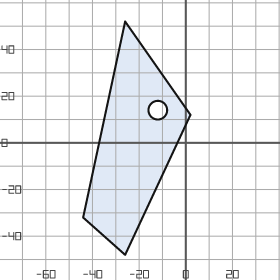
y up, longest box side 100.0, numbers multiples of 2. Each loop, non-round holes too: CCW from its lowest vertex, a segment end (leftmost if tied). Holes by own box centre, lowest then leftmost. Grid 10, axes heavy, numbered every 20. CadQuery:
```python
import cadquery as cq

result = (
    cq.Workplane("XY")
    .moveTo(-26.0, -48.0)
    .lineTo(2.0, 12.0)
    .lineTo(-26.0, 52.0)
    .lineTo(-44.0, -32.0)
    .close()
    .moveTo(-12.0, 14.0)
    .circle(4.0)
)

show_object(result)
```